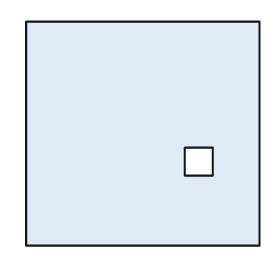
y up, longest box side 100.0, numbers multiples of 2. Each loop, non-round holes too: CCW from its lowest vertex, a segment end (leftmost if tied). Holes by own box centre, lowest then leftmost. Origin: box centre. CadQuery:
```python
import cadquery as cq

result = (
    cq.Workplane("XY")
    .moveTo(-50.0, -48.0)
    .lineTo(50.0, -48.0)
    .lineTo(50.0, 48.0)
    .lineTo(-50.0, 48.0)
    .close()
    .moveTo(18.0, -18.0)
    .lineTo(30.0, -18.0)
    .lineTo(30.0, -6.0)
    .lineTo(18.0, -6.0)
    .close()
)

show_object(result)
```